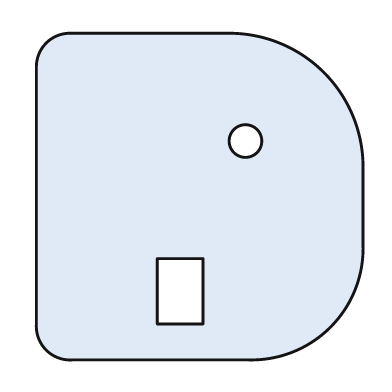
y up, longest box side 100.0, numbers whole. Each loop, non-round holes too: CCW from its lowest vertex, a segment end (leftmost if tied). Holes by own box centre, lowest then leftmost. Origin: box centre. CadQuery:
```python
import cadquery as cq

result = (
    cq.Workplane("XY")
    .moveTo(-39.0, -50.0)
    .lineTo(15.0, -50.0)
    .threePointArc((40.0, -40.0), (50.0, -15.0))
    .lineTo(50.0, 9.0)
    .threePointArc((38.0, 38.0), (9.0, 50.0))
    .lineTo(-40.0, 50.0)
    .threePointArc((-47.0, 47.0), (-50.0, 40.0))
    .lineTo(-50.0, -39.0)
    .threePointArc((-47.0, -47.0), (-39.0, -50.0))
    .close()
    .moveTo(-13.0, -39.0)
    .lineTo(1.0, -39.0)
    .lineTo(1.0, -19.0)
    .lineTo(-13.0, -19.0)
    .close()
    .moveTo(14.0, 17.0)
    .circle(5.0)
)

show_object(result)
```